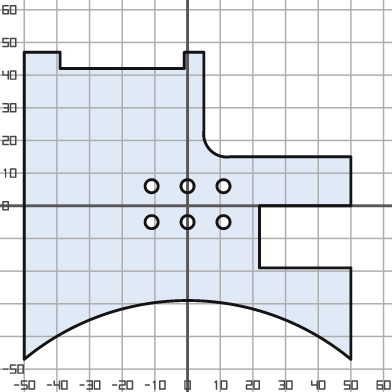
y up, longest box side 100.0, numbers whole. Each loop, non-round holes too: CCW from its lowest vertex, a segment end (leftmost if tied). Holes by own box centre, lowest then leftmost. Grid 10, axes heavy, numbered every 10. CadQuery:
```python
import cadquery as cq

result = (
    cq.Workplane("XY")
    .moveTo(-50.0, -47.0)
    .threePointArc((0.0, -29.0), (50.0, -47.0))
    .lineTo(50.0, -19.0)
    .lineTo(22.0, -19.0)
    .lineTo(22.0, 0.0)
    .lineTo(50.0, 0.0)
    .lineTo(50.0, 15.0)
    .lineTo(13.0, 15.0)
    .threePointArc((7.0, 17.0), (5.0, 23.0))
    .lineTo(5.0, 47.0)
    .lineTo(-1.0, 47.0)
    .lineTo(-1.0, 42.0)
    .lineTo(-39.0, 42.0)
    .lineTo(-39.0, 47.0)
    .lineTo(-50.0, 47.0)
    .close()
    .moveTo(-11.0, -5.0)
    .circle(2.0)
    .moveTo(0.0, -5.0)
    .circle(2.0)
    .moveTo(11.0, -5.0)
    .circle(2.0)
    .moveTo(-11.0, 6.0)
    .circle(2.0)
    .moveTo(0.0, 6.0)
    .circle(2.0)
    .moveTo(11.0, 6.0)
    .circle(2.0)
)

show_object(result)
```